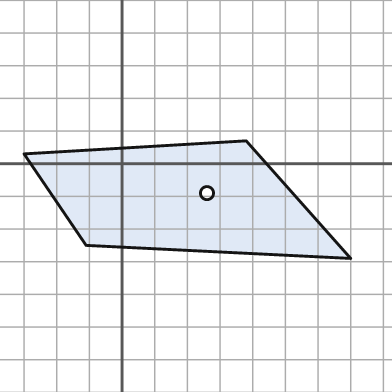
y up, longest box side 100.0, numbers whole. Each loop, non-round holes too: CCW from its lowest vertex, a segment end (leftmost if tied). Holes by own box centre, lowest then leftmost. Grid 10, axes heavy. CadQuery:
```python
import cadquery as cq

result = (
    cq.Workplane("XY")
    .moveTo(70.0, -29.0)
    .lineTo(38.0, 7.0)
    .lineTo(-30.0, 3.0)
    .lineTo(-11.0, -25.0)
    .close()
    .moveTo(26.0, -9.0)
    .circle(2.0)
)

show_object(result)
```